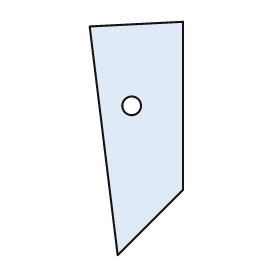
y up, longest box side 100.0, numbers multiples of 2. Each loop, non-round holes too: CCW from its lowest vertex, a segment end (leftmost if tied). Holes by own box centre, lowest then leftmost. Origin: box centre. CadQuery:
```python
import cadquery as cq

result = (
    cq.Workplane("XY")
    .moveTo(-8.0, -50.0)
    .lineTo(20.0, -22.0)
    .lineTo(20.0, 50.0)
    .lineTo(-20.0, 48.0)
    .close()
    .moveTo(-2.0, 14.0)
    .circle(4.0)
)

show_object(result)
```